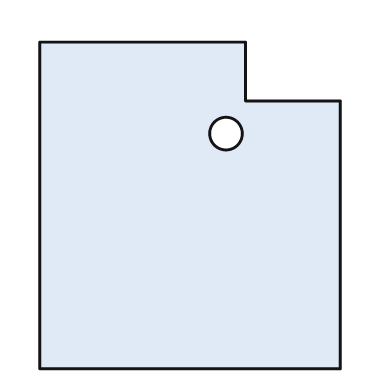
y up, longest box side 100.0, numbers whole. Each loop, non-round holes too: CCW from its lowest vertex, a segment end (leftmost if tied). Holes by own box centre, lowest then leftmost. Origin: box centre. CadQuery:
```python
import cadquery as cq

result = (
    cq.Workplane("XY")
    .moveTo(-46.0, -50.0)
    .lineTo(46.0, -50.0)
    .lineTo(46.0, 32.0)
    .lineTo(17.0, 32.0)
    .lineTo(17.0, 50.0)
    .lineTo(-46.0, 50.0)
    .close()
    .moveTo(11.0, 22.0)
    .circle(5.0)
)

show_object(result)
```